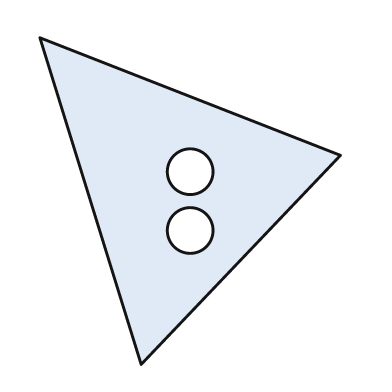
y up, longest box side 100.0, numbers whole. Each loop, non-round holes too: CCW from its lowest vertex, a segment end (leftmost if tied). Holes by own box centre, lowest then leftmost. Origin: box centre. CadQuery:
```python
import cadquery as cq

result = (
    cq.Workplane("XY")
    .moveTo(-15.0, -50.0)
    .lineTo(46.0, 14.0)
    .lineTo(-46.0, 50.0)
    .close()
    .moveTo(0.0, -9.0)
    .circle(7.0)
    .moveTo(0.0, 9.0)
    .circle(7.0)
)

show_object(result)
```